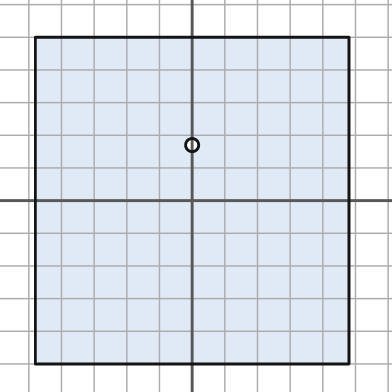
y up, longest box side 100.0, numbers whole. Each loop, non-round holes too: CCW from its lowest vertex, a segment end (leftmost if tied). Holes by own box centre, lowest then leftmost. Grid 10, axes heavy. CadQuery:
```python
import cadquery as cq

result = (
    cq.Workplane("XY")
    .moveTo(-48.0, -50.0)
    .lineTo(48.0, -50.0)
    .lineTo(48.0, 50.0)
    .lineTo(-48.0, 50.0)
    .close()
    .moveTo(0.0, 17.0)
    .circle(2.0)
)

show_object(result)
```